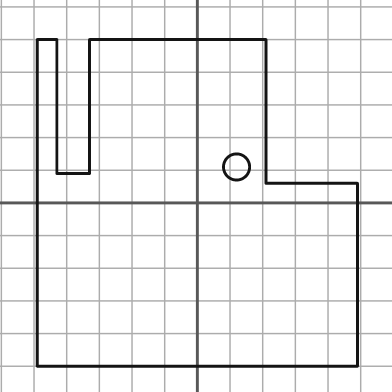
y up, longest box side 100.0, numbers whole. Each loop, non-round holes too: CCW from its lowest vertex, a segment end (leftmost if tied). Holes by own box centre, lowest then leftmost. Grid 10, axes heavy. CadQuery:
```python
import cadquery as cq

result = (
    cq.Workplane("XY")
    .moveTo(-49.0, -50.0)
    .lineTo(49.0, -50.0)
    .lineTo(49.0, 6.0)
    .lineTo(21.0, 6.0)
    .lineTo(21.0, 50.0)
    .lineTo(-33.0, 50.0)
    .lineTo(-33.0, 9.0)
    .lineTo(-43.0, 9.0)
    .lineTo(-43.0, 50.0)
    .lineTo(-49.0, 50.0)
    .close()
    .moveTo(12.0, 11.0)
    .circle(4.0)
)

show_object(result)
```